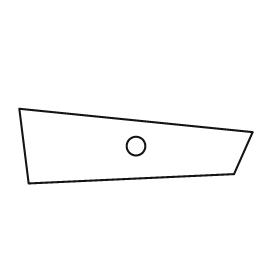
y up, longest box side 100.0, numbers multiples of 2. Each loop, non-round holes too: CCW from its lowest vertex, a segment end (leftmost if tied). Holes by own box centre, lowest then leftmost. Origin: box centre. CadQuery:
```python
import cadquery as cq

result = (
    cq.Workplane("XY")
    .moveTo(-46.0, -16.0)
    .lineTo(42.0, -12.0)
    .lineTo(50.0, 6.0)
    .lineTo(-50.0, 16.0)
    .close()
    .moveTo(0.0, 0.0)
    .circle(4.0)
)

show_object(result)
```